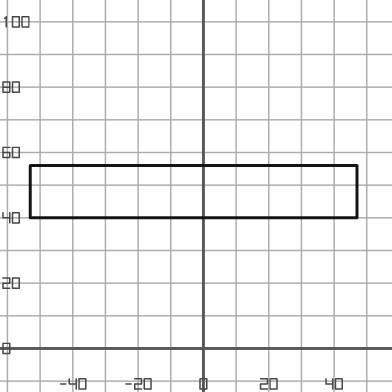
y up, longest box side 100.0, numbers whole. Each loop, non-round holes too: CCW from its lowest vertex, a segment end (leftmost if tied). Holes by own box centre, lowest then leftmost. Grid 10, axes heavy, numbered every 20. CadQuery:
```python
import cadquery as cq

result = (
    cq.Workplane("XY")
    .moveTo(-53.0, 40.0)
    .lineTo(47.0, 40.0)
    .lineTo(47.0, 56.0)
    .lineTo(-53.0, 56.0)
    .close()
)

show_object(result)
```